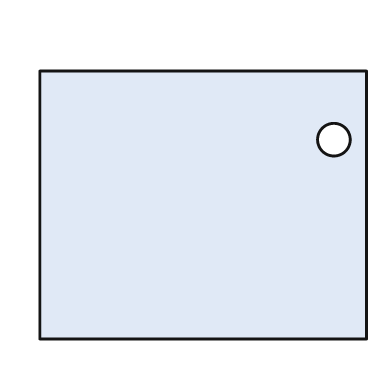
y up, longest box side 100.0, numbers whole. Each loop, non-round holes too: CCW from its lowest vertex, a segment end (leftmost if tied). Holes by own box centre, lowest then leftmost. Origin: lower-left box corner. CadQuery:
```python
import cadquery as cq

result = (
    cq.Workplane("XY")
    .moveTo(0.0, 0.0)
    .lineTo(100.0, 0.0)
    .lineTo(100.0, 82.0)
    .lineTo(0.0, 82.0)
    .close()
    .moveTo(90.0, 61.0)
    .circle(5.0)
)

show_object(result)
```